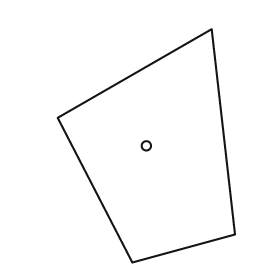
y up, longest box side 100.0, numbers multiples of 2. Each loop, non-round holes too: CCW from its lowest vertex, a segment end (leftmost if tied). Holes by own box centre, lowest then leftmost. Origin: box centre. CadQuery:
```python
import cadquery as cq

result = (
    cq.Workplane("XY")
    .moveTo(-6.0, -50.0)
    .lineTo(38.0, -38.0)
    .lineTo(28.0, 50.0)
    .lineTo(-38.0, 12.0)
    .close()
    .moveTo(0.0, 0.0)
    .circle(2.0)
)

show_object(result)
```